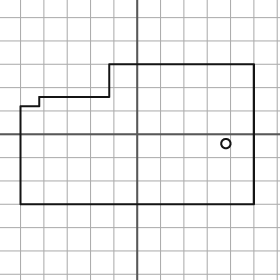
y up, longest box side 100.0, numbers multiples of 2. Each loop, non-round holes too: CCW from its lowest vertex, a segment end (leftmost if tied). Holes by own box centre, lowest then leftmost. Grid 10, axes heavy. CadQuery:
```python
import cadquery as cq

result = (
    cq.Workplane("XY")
    .moveTo(-50.0, -30.0)
    .lineTo(50.0, -30.0)
    .lineTo(50.0, 30.0)
    .lineTo(-12.0, 30.0)
    .lineTo(-12.0, 16.0)
    .lineTo(-42.0, 16.0)
    .lineTo(-42.0, 12.0)
    .lineTo(-50.0, 12.0)
    .close()
    .moveTo(38.0, -4.0)
    .circle(2.0)
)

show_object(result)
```